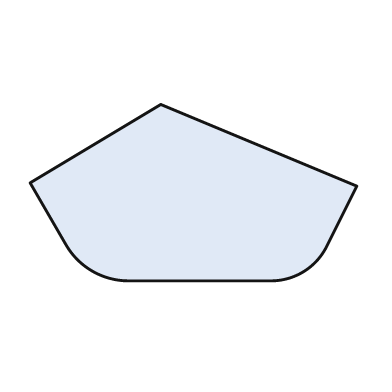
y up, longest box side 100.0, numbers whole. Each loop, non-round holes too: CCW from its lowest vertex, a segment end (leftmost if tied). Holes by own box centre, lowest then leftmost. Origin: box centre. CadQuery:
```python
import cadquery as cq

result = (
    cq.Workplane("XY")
    .moveTo(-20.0, -27.0)
    .lineTo(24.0, -27.0)
    .threePointArc((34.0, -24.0), (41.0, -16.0))
    .lineTo(50.0, 2.0)
    .lineTo(-10.0, 27.0)
    .lineTo(-50.0, 3.0)
    .lineTo(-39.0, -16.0)
    .threePointArc((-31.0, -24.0), (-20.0, -27.0))
    .close()
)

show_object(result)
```